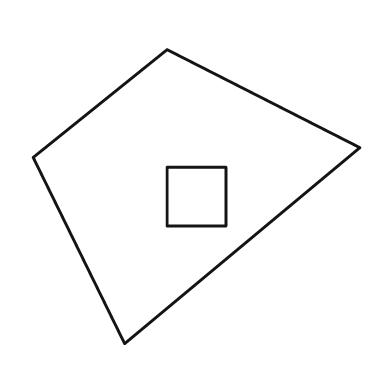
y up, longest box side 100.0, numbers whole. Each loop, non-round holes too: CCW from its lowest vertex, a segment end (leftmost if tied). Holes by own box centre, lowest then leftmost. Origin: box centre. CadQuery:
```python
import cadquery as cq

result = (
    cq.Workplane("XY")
    .moveTo(-22.0, -45.0)
    .lineTo(50.0, 15.0)
    .lineTo(-9.0, 45.0)
    .lineTo(-50.0, 12.0)
    .close()
    .moveTo(-9.0, -9.0)
    .lineTo(9.0, -9.0)
    .lineTo(9.0, 9.0)
    .lineTo(-9.0, 9.0)
    .close()
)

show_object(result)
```